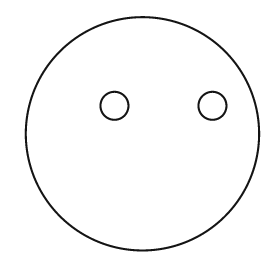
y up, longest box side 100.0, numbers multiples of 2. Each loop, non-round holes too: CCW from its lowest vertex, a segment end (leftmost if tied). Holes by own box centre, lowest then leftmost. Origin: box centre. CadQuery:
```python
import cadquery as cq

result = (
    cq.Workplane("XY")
    .moveTo(0.0, 0.0)
    .circle(50.0)
    .moveTo(-12.0, 12.0)
    .circle(6.0)
    .moveTo(30.0, 12.0)
    .circle(6.0)
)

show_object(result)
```